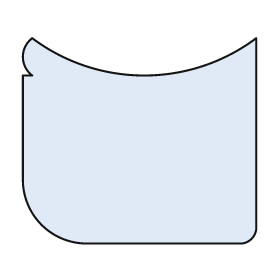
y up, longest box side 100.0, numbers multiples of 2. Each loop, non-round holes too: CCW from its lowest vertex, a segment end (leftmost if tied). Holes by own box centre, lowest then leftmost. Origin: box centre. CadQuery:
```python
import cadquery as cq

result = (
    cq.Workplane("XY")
    .moveTo(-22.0, -44.0)
    .lineTo(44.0, -44.0)
    .threePointArc((48.0, -42.0), (50.0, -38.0))
    .lineTo(50.0, 44.0)
    .threePointArc((2.0, 28.0), (-46.0, 44.0))
    .threePointArc((-50.0, 36.0), (-46.0, 28.0))
    .lineTo(-50.0, 28.0)
    .lineTo(-50.0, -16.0)
    .threePointArc((-42.0, -36.0), (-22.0, -44.0))
    .close()
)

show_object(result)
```